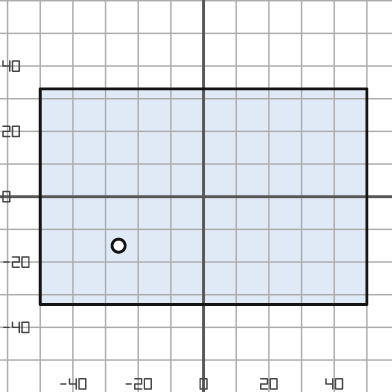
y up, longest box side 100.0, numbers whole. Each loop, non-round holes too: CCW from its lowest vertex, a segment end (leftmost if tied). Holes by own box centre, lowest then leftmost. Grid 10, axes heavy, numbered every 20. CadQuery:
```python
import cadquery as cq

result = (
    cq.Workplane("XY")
    .moveTo(-50.0, -33.0)
    .lineTo(50.0, -33.0)
    .lineTo(50.0, 33.0)
    .lineTo(-50.0, 33.0)
    .close()
    .moveTo(-26.0, -15.0)
    .circle(2.0)
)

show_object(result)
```